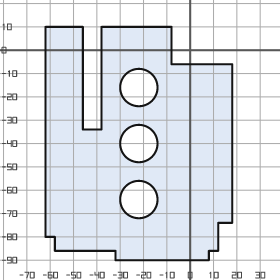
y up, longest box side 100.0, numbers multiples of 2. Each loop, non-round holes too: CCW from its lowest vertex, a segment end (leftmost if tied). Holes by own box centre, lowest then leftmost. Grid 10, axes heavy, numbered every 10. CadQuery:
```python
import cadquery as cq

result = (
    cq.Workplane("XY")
    .moveTo(-32.0, -90.0)
    .lineTo(8.0, -90.0)
    .lineTo(8.0, -86.0)
    .lineTo(12.0, -86.0)
    .lineTo(12.0, -74.0)
    .lineTo(18.0, -74.0)
    .lineTo(18.0, -6.0)
    .lineTo(-8.0, -6.0)
    .lineTo(-8.0, 10.0)
    .lineTo(-38.0, 10.0)
    .lineTo(-38.0, -34.0)
    .lineTo(-46.0, -34.0)
    .lineTo(-46.0, 10.0)
    .lineTo(-62.0, 10.0)
    .lineTo(-62.0, -80.0)
    .lineTo(-58.0, -80.0)
    .lineTo(-58.0, -86.0)
    .lineTo(-32.0, -86.0)
    .close()
    .moveTo(-22.0, -64.0)
    .circle(8.0)
    .moveTo(-22.0, -40.0)
    .circle(8.0)
    .moveTo(-22.0, -16.0)
    .circle(8.0)
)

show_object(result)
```